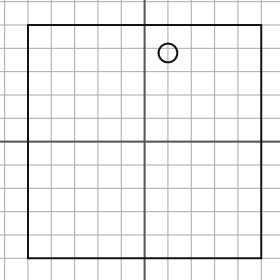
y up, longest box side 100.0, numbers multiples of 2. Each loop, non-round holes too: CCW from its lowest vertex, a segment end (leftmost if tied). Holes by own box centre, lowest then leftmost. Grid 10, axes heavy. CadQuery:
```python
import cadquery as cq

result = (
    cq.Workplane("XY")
    .moveTo(-50.0, -50.0)
    .lineTo(50.0, -50.0)
    .lineTo(50.0, 50.0)
    .lineTo(-50.0, 50.0)
    .close()
    .moveTo(10.0, 38.0)
    .circle(4.0)
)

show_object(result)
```